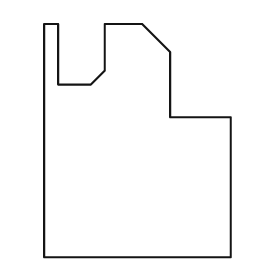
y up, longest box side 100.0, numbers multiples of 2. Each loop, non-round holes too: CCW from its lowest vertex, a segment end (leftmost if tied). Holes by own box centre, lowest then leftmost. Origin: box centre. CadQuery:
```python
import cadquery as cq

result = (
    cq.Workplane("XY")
    .moveTo(-40.0, -50.0)
    .lineTo(40.0, -50.0)
    .lineTo(40.0, 10.0)
    .lineTo(14.0, 10.0)
    .lineTo(14.0, 38.0)
    .lineTo(2.0, 50.0)
    .lineTo(-14.0, 50.0)
    .lineTo(-14.0, 30.0)
    .lineTo(-20.0, 24.0)
    .lineTo(-34.0, 24.0)
    .lineTo(-34.0, 50.0)
    .lineTo(-40.0, 50.0)
    .close()
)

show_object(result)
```